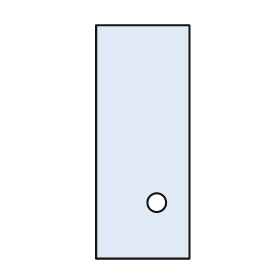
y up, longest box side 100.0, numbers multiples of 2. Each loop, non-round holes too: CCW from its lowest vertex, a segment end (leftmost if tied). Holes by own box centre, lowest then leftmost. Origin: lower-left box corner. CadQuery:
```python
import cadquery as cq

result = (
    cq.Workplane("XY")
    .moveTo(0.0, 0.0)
    .lineTo(40.0, 0.0)
    .lineTo(40.0, 100.0)
    .lineTo(0.0, 100.0)
    .close()
    .moveTo(26.0, 24.0)
    .circle(4.0)
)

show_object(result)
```